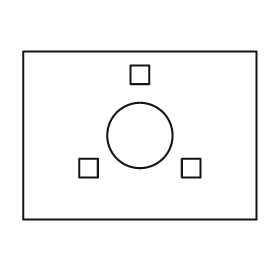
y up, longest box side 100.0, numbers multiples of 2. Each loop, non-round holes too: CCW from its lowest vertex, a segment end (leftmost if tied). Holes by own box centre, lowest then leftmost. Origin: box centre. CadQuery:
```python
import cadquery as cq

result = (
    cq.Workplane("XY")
    .moveTo(-50.0, -36.0)
    .lineTo(50.0, -36.0)
    .lineTo(50.0, 36.0)
    .lineTo(-50.0, 36.0)
    .close()
    .moveTo(-26.0, -18.0)
    .lineTo(-18.0, -18.0)
    .lineTo(-18.0, -10.0)
    .lineTo(-26.0, -10.0)
    .close()
    .moveTo(18.0, -18.0)
    .lineTo(26.0, -18.0)
    .lineTo(26.0, -10.0)
    .lineTo(18.0, -10.0)
    .close()
    .moveTo(0.0, 0.0)
    .circle(14.0)
    .moveTo(-4.0, 22.0)
    .lineTo(4.0, 22.0)
    .lineTo(4.0, 30.0)
    .lineTo(-4.0, 30.0)
    .close()
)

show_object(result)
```